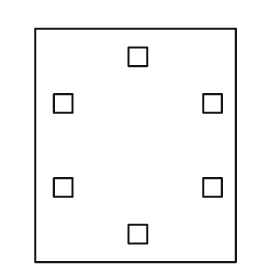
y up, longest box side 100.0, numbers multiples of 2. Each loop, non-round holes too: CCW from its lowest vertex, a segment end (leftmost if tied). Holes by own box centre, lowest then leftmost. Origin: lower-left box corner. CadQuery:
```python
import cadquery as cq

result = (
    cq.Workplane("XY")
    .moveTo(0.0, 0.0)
    .lineTo(86.0, 0.0)
    .lineTo(86.0, 100.0)
    .lineTo(0.0, 100.0)
    .close()
    .moveTo(40.0, 8.0)
    .lineTo(48.0, 8.0)
    .lineTo(48.0, 16.0)
    .lineTo(40.0, 16.0)
    .close()
    .moveTo(8.0, 28.0)
    .lineTo(16.0, 28.0)
    .lineTo(16.0, 36.0)
    .lineTo(8.0, 36.0)
    .close()
    .moveTo(72.0, 28.0)
    .lineTo(80.0, 28.0)
    .lineTo(80.0, 36.0)
    .lineTo(72.0, 36.0)
    .close()
    .moveTo(8.0, 64.0)
    .lineTo(16.0, 64.0)
    .lineTo(16.0, 72.0)
    .lineTo(8.0, 72.0)
    .close()
    .moveTo(72.0, 64.0)
    .lineTo(80.0, 64.0)
    .lineTo(80.0, 72.0)
    .lineTo(72.0, 72.0)
    .close()
    .moveTo(40.0, 84.0)
    .lineTo(48.0, 84.0)
    .lineTo(48.0, 92.0)
    .lineTo(40.0, 92.0)
    .close()
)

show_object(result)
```